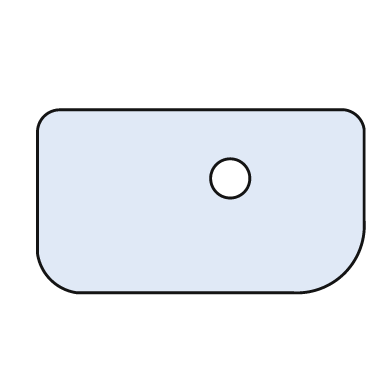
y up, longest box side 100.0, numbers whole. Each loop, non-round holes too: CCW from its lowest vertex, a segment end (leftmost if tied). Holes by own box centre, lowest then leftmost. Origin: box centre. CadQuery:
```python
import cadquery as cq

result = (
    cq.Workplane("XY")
    .moveTo(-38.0, -28.0)
    .lineTo(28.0, -28.0)
    .threePointArc((44.0, -22.0), (50.0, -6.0))
    .lineTo(50.0, 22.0)
    .threePointArc((48.0, 26.0), (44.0, 28.0))
    .lineTo(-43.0, 28.0)
    .threePointArc((-48.0, 26.0), (-50.0, 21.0))
    .lineTo(-50.0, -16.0)
    .threePointArc((-46.0, -24.0), (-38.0, -28.0))
    .close()
    .moveTo(9.0, 7.0)
    .circle(6.0)
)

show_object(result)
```